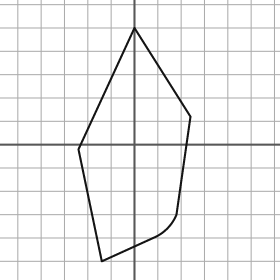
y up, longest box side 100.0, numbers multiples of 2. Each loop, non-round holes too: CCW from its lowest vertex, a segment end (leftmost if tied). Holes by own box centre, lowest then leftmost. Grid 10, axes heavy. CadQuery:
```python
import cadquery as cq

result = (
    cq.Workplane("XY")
    .moveTo(-14.0, -50.0)
    .lineTo(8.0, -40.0)
    .threePointArc((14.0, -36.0), (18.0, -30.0))
    .lineTo(24.0, 12.0)
    .lineTo(0.0, 50.0)
    .lineTo(-24.0, -2.0)
    .close()
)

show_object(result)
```